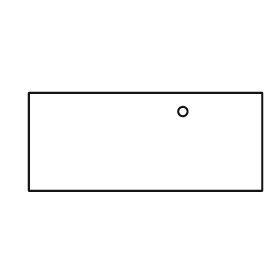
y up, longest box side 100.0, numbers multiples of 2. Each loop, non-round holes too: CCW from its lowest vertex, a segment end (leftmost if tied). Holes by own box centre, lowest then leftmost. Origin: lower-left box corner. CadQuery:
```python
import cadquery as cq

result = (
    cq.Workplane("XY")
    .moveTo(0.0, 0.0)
    .lineTo(100.0, 0.0)
    .lineTo(100.0, 42.0)
    .lineTo(0.0, 42.0)
    .close()
    .moveTo(66.0, 34.0)
    .circle(2.0)
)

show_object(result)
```